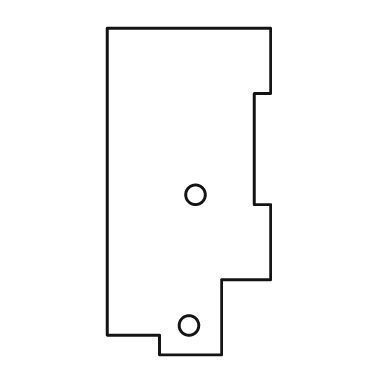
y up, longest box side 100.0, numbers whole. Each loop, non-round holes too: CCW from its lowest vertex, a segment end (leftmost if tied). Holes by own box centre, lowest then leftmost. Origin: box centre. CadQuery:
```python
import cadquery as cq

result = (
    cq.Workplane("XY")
    .moveTo(-9.0, -50.0)
    .lineTo(10.0, -50.0)
    .lineTo(10.0, -27.0)
    .lineTo(25.0, -27.0)
    .lineTo(25.0, -4.0)
    .lineTo(20.0, -4.0)
    .lineTo(20.0, 30.0)
    .lineTo(25.0, 30.0)
    .lineTo(25.0, 50.0)
    .lineTo(-25.0, 50.0)
    .lineTo(-25.0, -44.0)
    .lineTo(-9.0, -44.0)
    .close()
    .moveTo(0.0, -41.0)
    .circle(3.0)
    .moveTo(2.0, -1.0)
    .circle(3.0)
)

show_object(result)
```